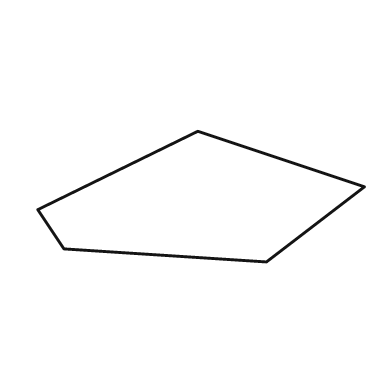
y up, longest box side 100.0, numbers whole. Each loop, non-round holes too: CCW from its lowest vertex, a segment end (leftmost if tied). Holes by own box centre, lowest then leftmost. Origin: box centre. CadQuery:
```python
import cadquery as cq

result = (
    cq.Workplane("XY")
    .moveTo(20.0, -20.0)
    .lineTo(50.0, 3.0)
    .lineTo(-1.0, 20.0)
    .lineTo(-50.0, -4.0)
    .lineTo(-42.0, -16.0)
    .close()
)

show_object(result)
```